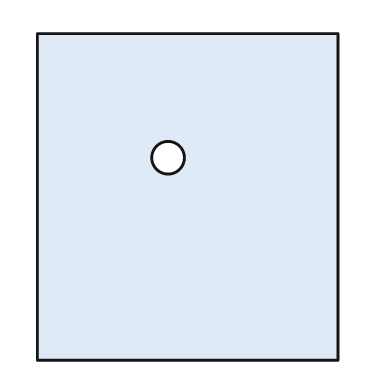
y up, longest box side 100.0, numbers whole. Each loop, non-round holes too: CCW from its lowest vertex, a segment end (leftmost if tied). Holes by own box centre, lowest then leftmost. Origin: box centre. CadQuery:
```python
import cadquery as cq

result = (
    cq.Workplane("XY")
    .moveTo(-46.0, -50.0)
    .lineTo(46.0, -50.0)
    .lineTo(46.0, 50.0)
    .lineTo(-46.0, 50.0)
    .close()
    .moveTo(-6.0, 12.0)
    .circle(5.0)
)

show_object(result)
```